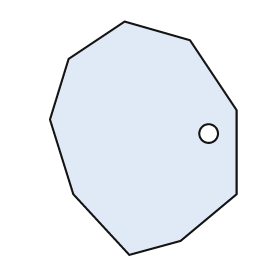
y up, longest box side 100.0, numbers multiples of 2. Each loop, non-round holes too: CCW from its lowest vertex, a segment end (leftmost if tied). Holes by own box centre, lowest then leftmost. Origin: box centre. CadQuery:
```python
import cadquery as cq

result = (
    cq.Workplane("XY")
    .moveTo(-6.0, -50.0)
    .lineTo(16.0, -44.0)
    .lineTo(40.0, -24.0)
    .lineTo(40.0, 12.0)
    .lineTo(20.0, 42.0)
    .lineTo(-8.0, 50.0)
    .lineTo(-32.0, 34.0)
    .lineTo(-40.0, 8.0)
    .lineTo(-30.0, -24.0)
    .close()
    .moveTo(28.0, 2.0)
    .circle(4.0)
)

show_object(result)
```